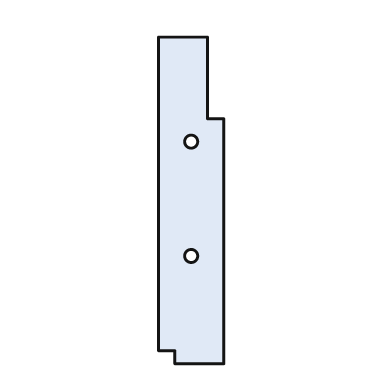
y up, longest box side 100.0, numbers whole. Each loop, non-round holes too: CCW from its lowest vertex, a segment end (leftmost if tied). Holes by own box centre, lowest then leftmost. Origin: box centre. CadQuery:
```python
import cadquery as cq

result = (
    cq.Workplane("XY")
    .moveTo(-5.0, -50.0)
    .lineTo(10.0, -50.0)
    .lineTo(10.0, 25.0)
    .lineTo(5.0, 25.0)
    .lineTo(5.0, 50.0)
    .lineTo(-10.0, 50.0)
    .lineTo(-10.0, -46.0)
    .lineTo(-5.0, -46.0)
    .close()
    .moveTo(0.0, -17.0)
    .circle(2.0)
    .moveTo(0.0, 18.0)
    .circle(2.0)
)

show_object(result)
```